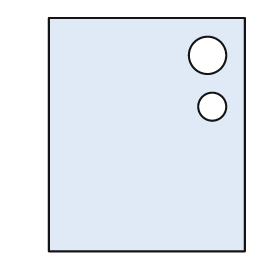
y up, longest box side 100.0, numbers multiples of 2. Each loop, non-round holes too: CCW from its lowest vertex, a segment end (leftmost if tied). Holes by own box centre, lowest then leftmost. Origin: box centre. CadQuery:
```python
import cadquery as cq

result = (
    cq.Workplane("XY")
    .moveTo(-42.0, -50.0)
    .lineTo(42.0, -50.0)
    .lineTo(42.0, 50.0)
    .lineTo(-42.0, 50.0)
    .close()
    .moveTo(28.0, 12.0)
    .circle(6.0)
    .moveTo(26.0, 34.0)
    .circle(8.0)
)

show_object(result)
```